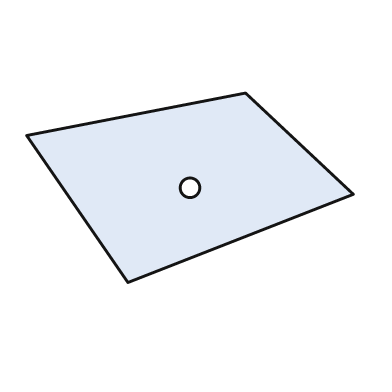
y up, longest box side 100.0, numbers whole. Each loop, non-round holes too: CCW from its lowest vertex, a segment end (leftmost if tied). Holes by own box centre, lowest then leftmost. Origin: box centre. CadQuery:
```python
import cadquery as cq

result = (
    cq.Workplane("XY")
    .moveTo(-19.0, -29.0)
    .lineTo(50.0, -2.0)
    .lineTo(17.0, 29.0)
    .lineTo(-50.0, 16.0)
    .close()
    .moveTo(0.0, 0.0)
    .circle(3.0)
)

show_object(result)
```